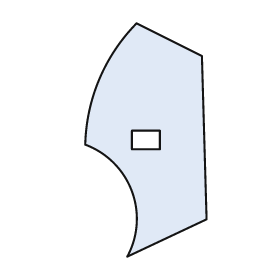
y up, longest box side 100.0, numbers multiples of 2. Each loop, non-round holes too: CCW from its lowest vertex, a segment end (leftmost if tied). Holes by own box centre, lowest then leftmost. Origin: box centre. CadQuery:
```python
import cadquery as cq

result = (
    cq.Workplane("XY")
    .moveTo(-8.0, -50.0)
    .lineTo(26.0, -34.0)
    .lineTo(24.0, 36.0)
    .lineTo(-4.0, 50.0)
    .threePointArc((-20.0, 26.0), (-26.0, -2.0))
    .threePointArc((-6.0, -22.0), (-8.0, -50.0))
    .close()
    .moveTo(-6.0, -4.0)
    .lineTo(6.0, -4.0)
    .lineTo(6.0, 4.0)
    .lineTo(-6.0, 4.0)
    .close()
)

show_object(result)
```